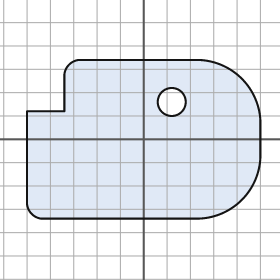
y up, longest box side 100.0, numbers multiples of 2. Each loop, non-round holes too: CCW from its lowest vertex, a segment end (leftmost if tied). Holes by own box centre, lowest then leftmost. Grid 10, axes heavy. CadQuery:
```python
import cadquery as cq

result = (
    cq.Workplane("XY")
    .moveTo(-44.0, -34.0)
    .lineTo(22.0, -34.0)
    .threePointArc((42.0, -26.0), (50.0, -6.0))
    .lineTo(50.0, 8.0)
    .threePointArc((42.0, 26.0), (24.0, 34.0))
    .lineTo(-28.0, 34.0)
    .threePointArc((-32.0, 32.0), (-34.0, 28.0))
    .lineTo(-34.0, 12.0)
    .lineTo(-50.0, 12.0)
    .lineTo(-50.0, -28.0)
    .threePointArc((-48.0, -32.0), (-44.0, -34.0))
    .close()
    .moveTo(12.0, 16.0)
    .circle(6.0)
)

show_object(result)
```